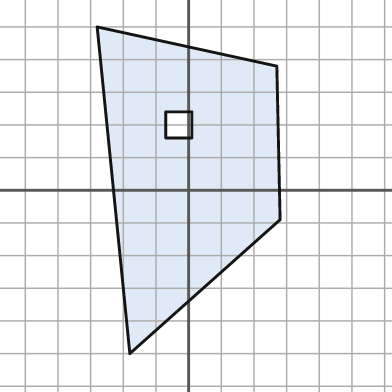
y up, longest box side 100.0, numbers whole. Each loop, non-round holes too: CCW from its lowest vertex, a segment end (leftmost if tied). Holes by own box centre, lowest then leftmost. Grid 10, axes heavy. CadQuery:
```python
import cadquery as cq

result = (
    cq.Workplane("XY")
    .moveTo(-18.0, -50.0)
    .lineTo(28.0, -9.0)
    .lineTo(27.0, 38.0)
    .lineTo(-28.0, 50.0)
    .close()
    .moveTo(-7.0, 16.0)
    .lineTo(1.0, 16.0)
    .lineTo(1.0, 24.0)
    .lineTo(-7.0, 24.0)
    .close()
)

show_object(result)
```